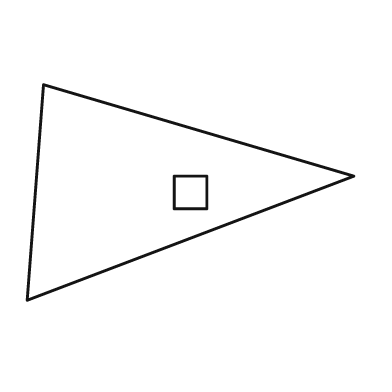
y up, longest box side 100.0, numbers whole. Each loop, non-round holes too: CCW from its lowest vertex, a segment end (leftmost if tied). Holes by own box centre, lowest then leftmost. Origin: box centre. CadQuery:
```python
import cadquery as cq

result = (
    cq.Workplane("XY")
    .moveTo(-50.0, -33.0)
    .lineTo(50.0, 5.0)
    .lineTo(-45.0, 33.0)
    .close()
    .moveTo(-5.0, -5.0)
    .lineTo(5.0, -5.0)
    .lineTo(5.0, 5.0)
    .lineTo(-5.0, 5.0)
    .close()
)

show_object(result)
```